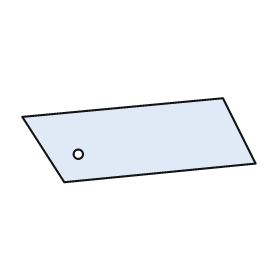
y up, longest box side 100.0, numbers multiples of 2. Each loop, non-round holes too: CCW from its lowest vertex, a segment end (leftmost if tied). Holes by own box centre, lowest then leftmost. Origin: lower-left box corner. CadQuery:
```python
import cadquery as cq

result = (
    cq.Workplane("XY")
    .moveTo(18.0, 0.0)
    .lineTo(100.0, 8.0)
    .lineTo(86.0, 36.0)
    .lineTo(0.0, 28.0)
    .close()
    .moveTo(24.0, 12.0)
    .circle(2.0)
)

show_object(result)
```